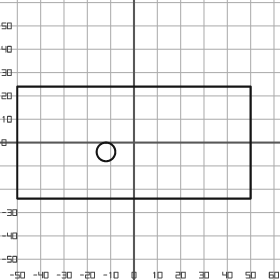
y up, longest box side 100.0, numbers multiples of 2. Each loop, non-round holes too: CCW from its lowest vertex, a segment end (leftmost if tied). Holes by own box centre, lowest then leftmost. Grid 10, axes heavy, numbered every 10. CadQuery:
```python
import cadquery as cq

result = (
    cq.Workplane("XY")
    .moveTo(-50.0, -24.0)
    .lineTo(50.0, -24.0)
    .lineTo(50.0, 24.0)
    .lineTo(-50.0, 24.0)
    .close()
    .moveTo(-12.0, -4.0)
    .circle(4.0)
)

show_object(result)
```